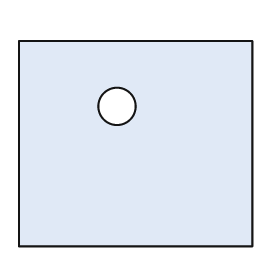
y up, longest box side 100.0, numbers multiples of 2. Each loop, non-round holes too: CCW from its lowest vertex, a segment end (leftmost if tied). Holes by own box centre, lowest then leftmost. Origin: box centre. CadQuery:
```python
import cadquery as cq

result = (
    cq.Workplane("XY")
    .moveTo(-50.0, -44.0)
    .lineTo(50.0, -44.0)
    .lineTo(50.0, 44.0)
    .lineTo(-50.0, 44.0)
    .close()
    .moveTo(-8.0, 16.0)
    .circle(8.0)
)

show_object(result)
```